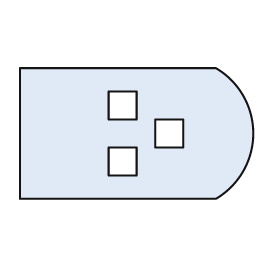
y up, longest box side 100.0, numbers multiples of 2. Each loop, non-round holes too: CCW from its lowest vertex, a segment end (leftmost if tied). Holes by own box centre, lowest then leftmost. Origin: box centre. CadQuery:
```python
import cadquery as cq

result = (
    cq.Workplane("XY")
    .moveTo(-50.0, -28.0)
    .lineTo(34.0, -28.0)
    .threePointArc((50.0, 0.0), (34.0, 28.0))
    .lineTo(-50.0, 28.0)
    .close()
    .moveTo(-12.0, -18.0)
    .lineTo(0.0, -18.0)
    .lineTo(0.0, -6.0)
    .lineTo(-12.0, -6.0)
    .close()
    .moveTo(8.0, -6.0)
    .lineTo(20.0, -6.0)
    .lineTo(20.0, 6.0)
    .lineTo(8.0, 6.0)
    .close()
    .moveTo(-12.0, 6.0)
    .lineTo(0.0, 6.0)
    .lineTo(0.0, 18.0)
    .lineTo(-12.0, 18.0)
    .close()
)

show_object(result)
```